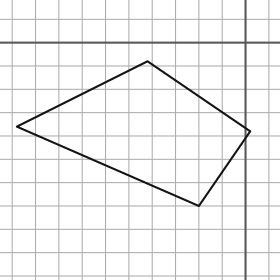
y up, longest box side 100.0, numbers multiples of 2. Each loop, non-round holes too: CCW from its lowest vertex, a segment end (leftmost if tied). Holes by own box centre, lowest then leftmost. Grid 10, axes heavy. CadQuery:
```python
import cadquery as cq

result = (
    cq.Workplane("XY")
    .moveTo(-20.0, -70.0)
    .lineTo(2.0, -38.0)
    .lineTo(-42.0, -8.0)
    .lineTo(-98.0, -36.0)
    .close()
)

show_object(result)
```